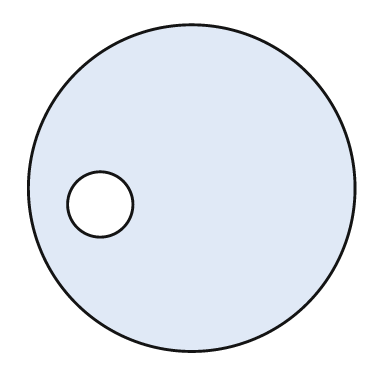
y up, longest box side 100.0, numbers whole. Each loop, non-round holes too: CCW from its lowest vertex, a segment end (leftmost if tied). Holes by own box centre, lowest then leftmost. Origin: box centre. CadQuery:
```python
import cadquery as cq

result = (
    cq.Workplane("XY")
    .moveTo(0.0, 0.0)
    .circle(50.0)
    .moveTo(-28.0, -5.0)
    .circle(10.0)
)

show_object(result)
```